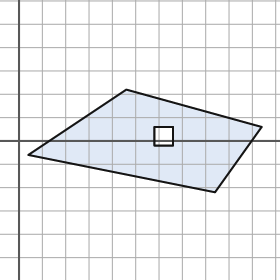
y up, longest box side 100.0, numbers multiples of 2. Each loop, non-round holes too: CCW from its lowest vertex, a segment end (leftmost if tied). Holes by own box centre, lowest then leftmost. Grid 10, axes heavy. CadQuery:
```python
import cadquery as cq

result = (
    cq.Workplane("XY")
    .moveTo(84.0, -22.0)
    .lineTo(104.0, 6.0)
    .lineTo(46.0, 22.0)
    .lineTo(4.0, -6.0)
    .close()
    .moveTo(58.0, -2.0)
    .lineTo(66.0, -2.0)
    .lineTo(66.0, 6.0)
    .lineTo(58.0, 6.0)
    .close()
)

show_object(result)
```